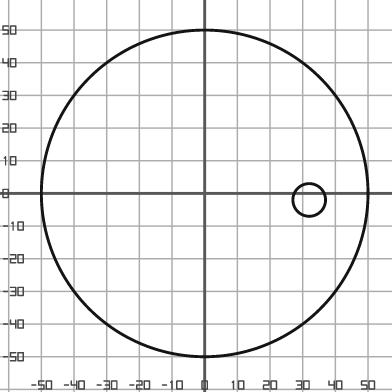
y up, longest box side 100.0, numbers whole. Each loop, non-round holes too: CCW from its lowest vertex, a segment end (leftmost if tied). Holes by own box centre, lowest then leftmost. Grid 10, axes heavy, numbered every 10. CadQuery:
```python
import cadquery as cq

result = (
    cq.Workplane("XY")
    .moveTo(0.0, 0.0)
    .circle(50.0)
    .moveTo(32.0, -2.0)
    .circle(5.0)
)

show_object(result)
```